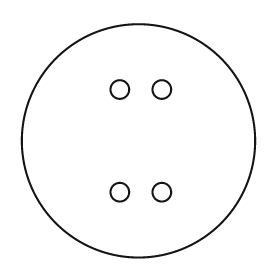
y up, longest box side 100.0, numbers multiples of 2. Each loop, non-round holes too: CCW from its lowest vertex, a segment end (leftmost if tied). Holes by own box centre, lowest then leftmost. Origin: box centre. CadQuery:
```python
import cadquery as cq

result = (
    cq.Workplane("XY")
    .moveTo(0.0, 0.0)
    .circle(50.0)
    .moveTo(-8.0, -22.0)
    .circle(4.0)
    .moveTo(10.0, -22.0)
    .circle(4.0)
    .moveTo(-8.0, 22.0)
    .circle(4.0)
    .moveTo(10.0, 22.0)
    .circle(4.0)
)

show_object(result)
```